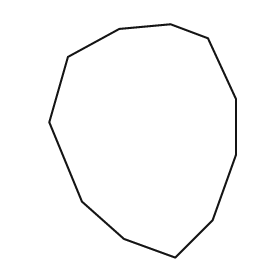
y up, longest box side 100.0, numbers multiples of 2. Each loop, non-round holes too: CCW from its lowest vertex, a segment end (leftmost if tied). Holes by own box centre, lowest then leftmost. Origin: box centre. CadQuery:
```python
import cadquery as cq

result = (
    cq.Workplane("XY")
    .moveTo(14.0, -50.0)
    .lineTo(30.0, -34.0)
    .lineTo(40.0, -6.0)
    .lineTo(40.0, 18.0)
    .lineTo(28.0, 44.0)
    .lineTo(12.0, 50.0)
    .lineTo(-10.0, 48.0)
    .lineTo(-32.0, 36.0)
    .lineTo(-40.0, 8.0)
    .lineTo(-26.0, -26.0)
    .lineTo(-8.0, -42.0)
    .close()
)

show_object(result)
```